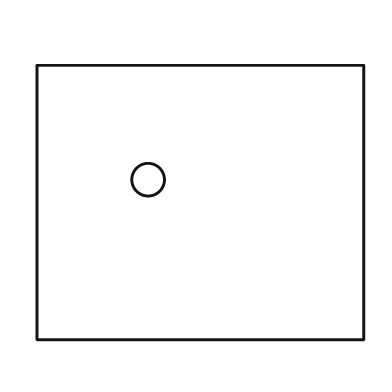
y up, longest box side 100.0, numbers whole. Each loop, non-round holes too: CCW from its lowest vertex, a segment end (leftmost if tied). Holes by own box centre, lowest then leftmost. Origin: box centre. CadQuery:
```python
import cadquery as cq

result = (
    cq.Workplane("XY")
    .moveTo(-50.0, -42.0)
    .lineTo(50.0, -42.0)
    .lineTo(50.0, 42.0)
    .lineTo(-50.0, 42.0)
    .close()
    .moveTo(-16.0, 7.0)
    .circle(5.0)
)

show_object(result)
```